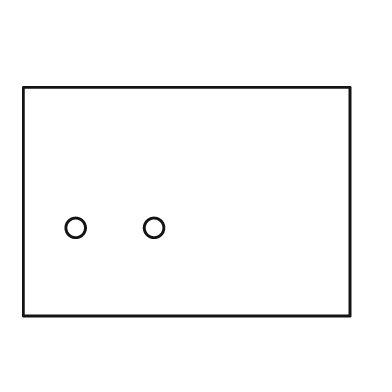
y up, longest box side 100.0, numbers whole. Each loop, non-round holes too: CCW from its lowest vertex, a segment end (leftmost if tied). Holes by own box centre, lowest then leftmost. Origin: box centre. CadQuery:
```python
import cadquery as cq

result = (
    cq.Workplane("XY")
    .moveTo(-50.0, -35.0)
    .lineTo(50.0, -35.0)
    .lineTo(50.0, 35.0)
    .lineTo(-50.0, 35.0)
    .close()
    .moveTo(-34.0, -8.0)
    .circle(3.0)
    .moveTo(-10.0, -8.0)
    .circle(3.0)
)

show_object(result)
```